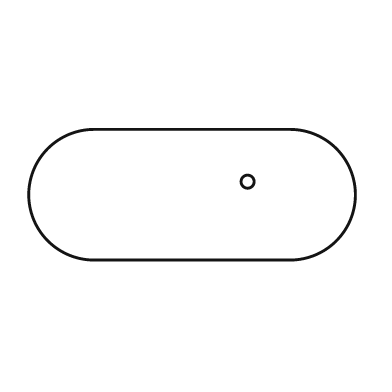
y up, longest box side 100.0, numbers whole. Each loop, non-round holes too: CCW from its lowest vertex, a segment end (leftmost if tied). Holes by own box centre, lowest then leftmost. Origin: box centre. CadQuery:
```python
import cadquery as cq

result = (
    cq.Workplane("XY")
    .moveTo(-30.0, -20.0)
    .lineTo(30.0, -20.0)
    .threePointArc((50.0, 0.0), (30.0, 20.0))
    .lineTo(-30.0, 20.0)
    .threePointArc((-50.0, 0.0), (-30.0, -20.0))
    .close()
    .moveTo(17.0, 4.0)
    .circle(2.0)
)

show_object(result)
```